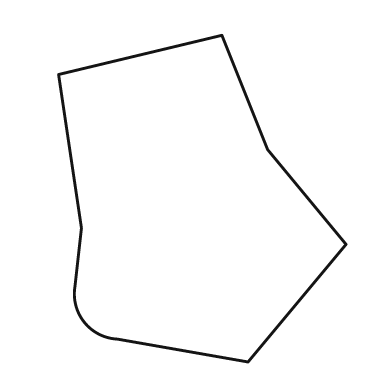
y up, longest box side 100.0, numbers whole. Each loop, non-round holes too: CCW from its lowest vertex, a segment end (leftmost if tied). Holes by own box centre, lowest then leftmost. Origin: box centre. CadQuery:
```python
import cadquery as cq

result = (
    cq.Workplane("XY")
    .moveTo(14.0, -50.0)
    .lineTo(44.0, -14.0)
    .lineTo(20.0, 15.0)
    .lineTo(6.0, 50.0)
    .lineTo(-44.0, 38.0)
    .lineTo(-37.0, -9.0)
    .lineTo(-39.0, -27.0)
    .threePointArc((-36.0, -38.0), (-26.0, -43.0))
    .close()
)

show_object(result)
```